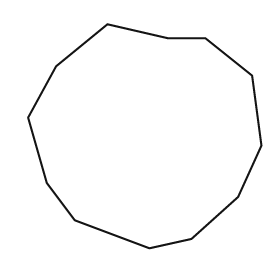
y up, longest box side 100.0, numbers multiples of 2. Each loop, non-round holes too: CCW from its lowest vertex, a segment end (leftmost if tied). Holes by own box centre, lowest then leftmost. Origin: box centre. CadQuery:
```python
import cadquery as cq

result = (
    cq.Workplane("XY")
    .moveTo(2.0, -48.0)
    .lineTo(20.0, -44.0)
    .lineTo(40.0, -26.0)
    .lineTo(50.0, -4.0)
    .lineTo(46.0, 26.0)
    .lineTo(26.0, 42.0)
    .lineTo(10.0, 42.0)
    .lineTo(-16.0, 48.0)
    .lineTo(-38.0, 30.0)
    .lineTo(-50.0, 8.0)
    .lineTo(-42.0, -20.0)
    .lineTo(-30.0, -36.0)
    .close()
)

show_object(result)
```